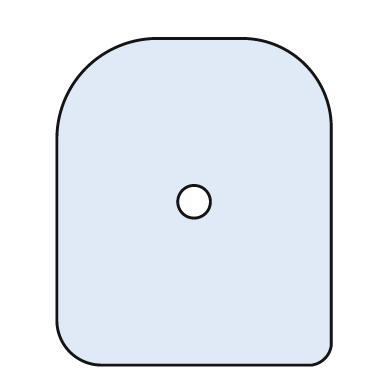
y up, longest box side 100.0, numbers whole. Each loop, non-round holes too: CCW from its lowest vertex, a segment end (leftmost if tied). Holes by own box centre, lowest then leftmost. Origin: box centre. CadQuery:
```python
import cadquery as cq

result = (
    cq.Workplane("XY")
    .moveTo(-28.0, -50.0)
    .lineTo(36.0, -50.0)
    .threePointArc((40.0, -48.0), (42.0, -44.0))
    .lineTo(42.0, 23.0)
    .threePointArc((34.0, 42.0), (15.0, 50.0))
    .lineTo(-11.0, 50.0)
    .threePointArc((-33.0, 41.0), (-42.0, 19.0))
    .lineTo(-42.0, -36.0)
    .threePointArc((-38.0, -46.0), (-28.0, -50.0))
    .close()
    .moveTo(0.0, 0.0)
    .circle(5.0)
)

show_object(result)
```